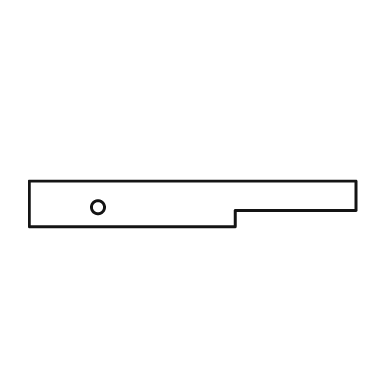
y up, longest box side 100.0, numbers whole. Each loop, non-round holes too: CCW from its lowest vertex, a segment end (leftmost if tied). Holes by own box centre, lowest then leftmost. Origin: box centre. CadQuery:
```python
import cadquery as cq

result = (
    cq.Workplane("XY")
    .moveTo(-50.0, -7.0)
    .lineTo(13.0, -7.0)
    .lineTo(13.0, -2.0)
    .lineTo(50.0, -2.0)
    .lineTo(50.0, 7.0)
    .lineTo(-50.0, 7.0)
    .close()
    .moveTo(-29.0, -1.0)
    .circle(2.0)
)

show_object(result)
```